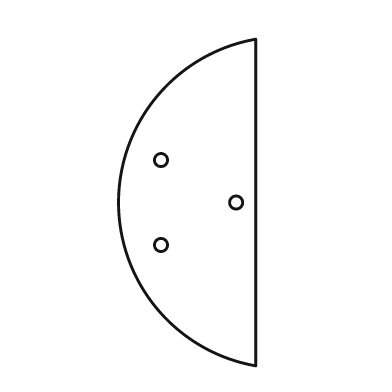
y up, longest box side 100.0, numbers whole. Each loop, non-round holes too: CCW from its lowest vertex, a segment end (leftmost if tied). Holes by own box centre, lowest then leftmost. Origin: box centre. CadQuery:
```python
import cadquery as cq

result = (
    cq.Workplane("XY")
    .moveTo(21.0, -50.0)
    .lineTo(21.0, 50.0)
    .threePointArc((-21.0, 0.0), (21.0, -50.0))
    .close()
    .moveTo(-8.0, -13.0)
    .circle(2.0)
    .moveTo(15.0, 0.0)
    .circle(2.0)
    .moveTo(-8.0, 13.0)
    .circle(2.0)
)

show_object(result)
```